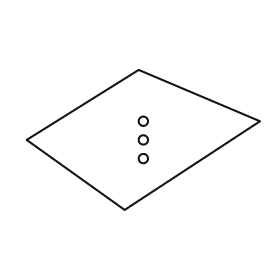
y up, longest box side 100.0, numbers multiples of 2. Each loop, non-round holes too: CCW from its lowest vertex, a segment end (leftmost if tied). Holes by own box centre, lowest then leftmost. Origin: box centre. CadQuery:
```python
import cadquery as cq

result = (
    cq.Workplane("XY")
    .moveTo(-8.0, -30.0)
    .lineTo(50.0, 8.0)
    .lineTo(-2.0, 30.0)
    .lineTo(-50.0, 0.0)
    .close()
    .moveTo(0.0, -8.0)
    .circle(2.0)
    .moveTo(0.0, 0.0)
    .circle(2.0)
    .moveTo(0.0, 8.0)
    .circle(2.0)
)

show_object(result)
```